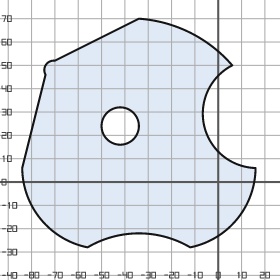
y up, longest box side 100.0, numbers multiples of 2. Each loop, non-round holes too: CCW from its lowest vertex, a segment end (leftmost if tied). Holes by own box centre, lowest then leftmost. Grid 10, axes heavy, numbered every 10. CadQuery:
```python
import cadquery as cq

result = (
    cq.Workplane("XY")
    .moveTo(-56.0, -28.0)
    .threePointArc((-34.0, -22.0), (-12.0, -28.0))
    .threePointArc((8.0, -16.0), (16.0, 6.0))
    .threePointArc((-6.0, 24.0), (6.0, 50.0))
    .threePointArc((-12.0, 64.0), (-34.0, 70.0))
    .lineTo(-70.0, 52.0)
    .threePointArc((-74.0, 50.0), (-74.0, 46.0))
    .lineTo(-84.0, 6.0)
    .threePointArc((-76.0, -16.0), (-56.0, -28.0))
    .close()
    .moveTo(-42.0, 24.0)
    .circle(8.0)
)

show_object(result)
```